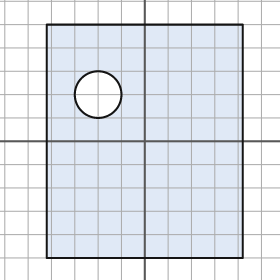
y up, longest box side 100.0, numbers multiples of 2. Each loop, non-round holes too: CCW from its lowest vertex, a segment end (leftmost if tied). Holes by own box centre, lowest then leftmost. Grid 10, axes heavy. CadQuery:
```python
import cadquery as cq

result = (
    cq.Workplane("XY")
    .moveTo(-42.0, -50.0)
    .lineTo(42.0, -50.0)
    .lineTo(42.0, 50.0)
    .lineTo(-42.0, 50.0)
    .close()
    .moveTo(-20.0, 20.0)
    .circle(10.0)
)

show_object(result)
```